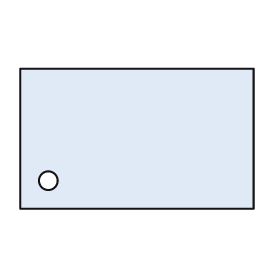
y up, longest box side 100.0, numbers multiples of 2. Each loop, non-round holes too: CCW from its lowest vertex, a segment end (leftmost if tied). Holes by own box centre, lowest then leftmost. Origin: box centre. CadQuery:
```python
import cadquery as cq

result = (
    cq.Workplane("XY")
    .moveTo(-50.0, -30.0)
    .lineTo(50.0, -30.0)
    .lineTo(50.0, 30.0)
    .lineTo(-50.0, 30.0)
    .close()
    .moveTo(-38.0, -18.0)
    .circle(4.0)
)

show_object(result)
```